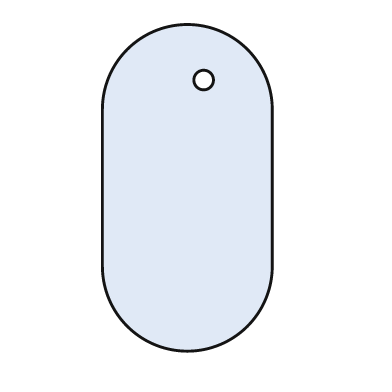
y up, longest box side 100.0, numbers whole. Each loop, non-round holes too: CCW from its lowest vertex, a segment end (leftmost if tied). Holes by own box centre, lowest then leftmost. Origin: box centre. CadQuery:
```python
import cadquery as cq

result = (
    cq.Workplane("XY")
    .moveTo(-26.0, -24.0)
    .threePointArc((0.0, -50.0), (26.0, -24.0))
    .lineTo(26.0, 24.0)
    .threePointArc((0.0, 50.0), (-26.0, 24.0))
    .close()
    .moveTo(5.0, 33.0)
    .circle(3.0)
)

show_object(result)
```